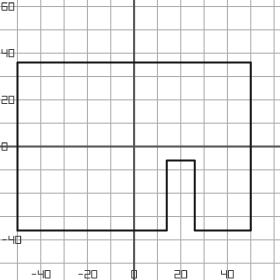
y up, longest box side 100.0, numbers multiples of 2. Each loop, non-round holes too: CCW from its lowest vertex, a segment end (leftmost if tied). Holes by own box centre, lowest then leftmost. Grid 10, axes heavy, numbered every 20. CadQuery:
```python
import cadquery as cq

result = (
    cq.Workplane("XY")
    .moveTo(-50.0, -36.0)
    .lineTo(14.0, -36.0)
    .lineTo(14.0, -6.0)
    .lineTo(26.0, -6.0)
    .lineTo(26.0, -36.0)
    .lineTo(50.0, -36.0)
    .lineTo(50.0, 36.0)
    .lineTo(-50.0, 36.0)
    .close()
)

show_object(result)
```